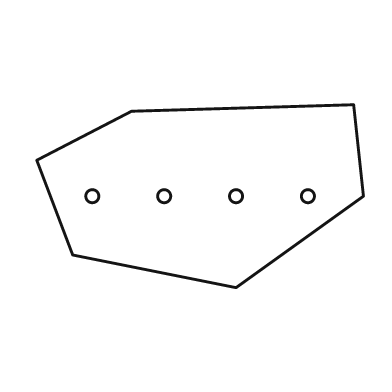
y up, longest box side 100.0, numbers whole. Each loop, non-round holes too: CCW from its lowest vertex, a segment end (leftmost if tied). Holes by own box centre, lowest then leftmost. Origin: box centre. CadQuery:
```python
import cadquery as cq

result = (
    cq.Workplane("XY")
    .moveTo(11.0, -28.0)
    .lineTo(50.0, 0.0)
    .lineTo(47.0, 28.0)
    .lineTo(-21.0, 26.0)
    .lineTo(-50.0, 11.0)
    .lineTo(-39.0, -18.0)
    .close()
    .moveTo(-33.0, 0.0)
    .circle(2.0)
    .moveTo(-11.0, 0.0)
    .circle(2.0)
    .moveTo(11.0, 0.0)
    .circle(2.0)
    .moveTo(33.0, 0.0)
    .circle(2.0)
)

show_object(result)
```